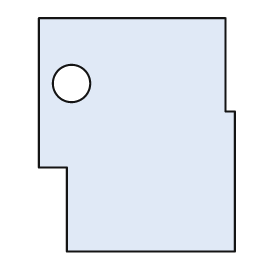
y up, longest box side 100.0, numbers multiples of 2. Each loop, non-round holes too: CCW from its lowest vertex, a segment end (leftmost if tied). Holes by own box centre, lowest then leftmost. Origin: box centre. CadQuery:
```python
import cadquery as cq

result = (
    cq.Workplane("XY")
    .moveTo(-30.0, -50.0)
    .lineTo(42.0, -50.0)
    .lineTo(42.0, 10.0)
    .lineTo(38.0, 10.0)
    .lineTo(38.0, 50.0)
    .lineTo(-42.0, 50.0)
    .lineTo(-42.0, -14.0)
    .lineTo(-30.0, -14.0)
    .close()
    .moveTo(-28.0, 22.0)
    .circle(8.0)
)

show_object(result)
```